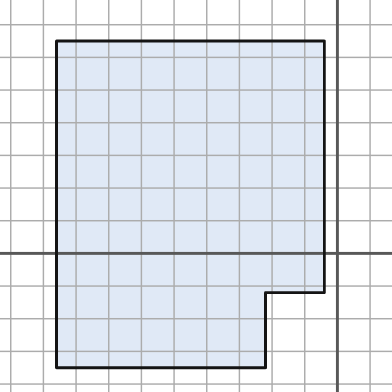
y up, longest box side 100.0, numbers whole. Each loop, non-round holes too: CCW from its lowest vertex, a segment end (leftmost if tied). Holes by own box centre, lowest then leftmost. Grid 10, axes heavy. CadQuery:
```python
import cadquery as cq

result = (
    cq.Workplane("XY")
    .moveTo(-86.0, -35.0)
    .lineTo(-22.0, -35.0)
    .lineTo(-22.0, -12.0)
    .lineTo(-4.0, -12.0)
    .lineTo(-4.0, 65.0)
    .lineTo(-86.0, 65.0)
    .close()
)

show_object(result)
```